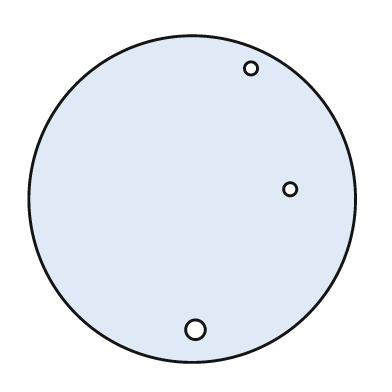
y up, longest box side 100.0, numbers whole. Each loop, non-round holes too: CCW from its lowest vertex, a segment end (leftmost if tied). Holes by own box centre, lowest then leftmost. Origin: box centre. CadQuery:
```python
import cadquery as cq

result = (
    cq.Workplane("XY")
    .moveTo(0.0, 0.0)
    .circle(50.0)
    .moveTo(1.0, -40.0)
    .circle(3.0)
    .moveTo(30.0, 3.0)
    .circle(2.0)
    .moveTo(18.0, 40.0)
    .circle(2.0)
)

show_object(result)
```